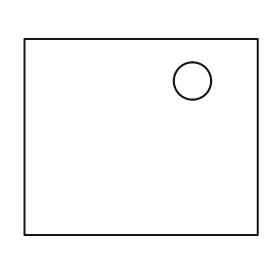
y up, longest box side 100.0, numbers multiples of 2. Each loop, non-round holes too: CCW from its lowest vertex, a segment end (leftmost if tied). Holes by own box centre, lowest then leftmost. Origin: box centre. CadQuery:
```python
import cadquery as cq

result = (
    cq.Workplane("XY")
    .moveTo(-50.0, -42.0)
    .lineTo(50.0, -42.0)
    .lineTo(50.0, 42.0)
    .lineTo(-50.0, 42.0)
    .close()
    .moveTo(22.0, 24.0)
    .circle(8.0)
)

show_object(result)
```